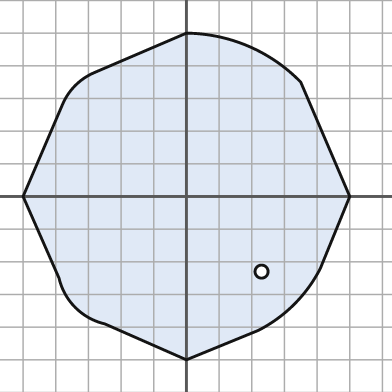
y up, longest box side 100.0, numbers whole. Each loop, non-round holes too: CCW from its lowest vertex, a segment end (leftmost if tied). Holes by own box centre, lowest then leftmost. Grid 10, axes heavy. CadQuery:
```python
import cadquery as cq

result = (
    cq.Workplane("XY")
    .moveTo(0.0, -50.0)
    .lineTo(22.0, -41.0)
    .threePointArc((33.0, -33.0), (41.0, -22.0))
    .lineTo(50.0, 0.0)
    .lineTo(35.0, 35.0)
    .threePointArc((19.0, 46.0), (0.0, 50.0))
    .lineTo(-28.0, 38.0)
    .threePointArc((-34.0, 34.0), (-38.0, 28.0))
    .lineTo(-50.0, 0.0)
    .lineTo(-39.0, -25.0)
    .threePointArc((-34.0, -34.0), (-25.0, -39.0))
    .close()
    .moveTo(23.0, -23.0)
    .circle(2.0)
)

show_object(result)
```